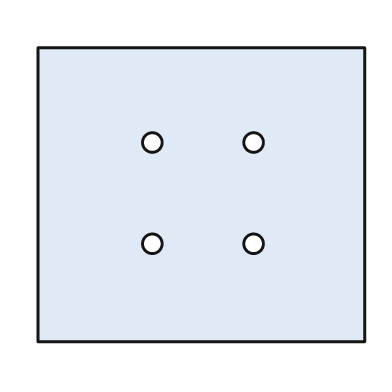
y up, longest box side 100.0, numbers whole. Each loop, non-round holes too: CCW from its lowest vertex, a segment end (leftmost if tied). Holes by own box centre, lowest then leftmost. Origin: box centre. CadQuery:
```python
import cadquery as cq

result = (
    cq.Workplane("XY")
    .moveTo(-50.0, -45.0)
    .lineTo(50.0, -45.0)
    .lineTo(50.0, 45.0)
    .lineTo(-50.0, 45.0)
    .close()
    .moveTo(-15.0, -15.0)
    .circle(3.0)
    .moveTo(16.0, -15.0)
    .circle(3.0)
    .moveTo(-15.0, 16.0)
    .circle(3.0)
    .moveTo(16.0, 16.0)
    .circle(3.0)
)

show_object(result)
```